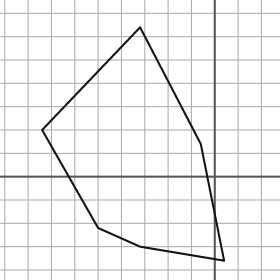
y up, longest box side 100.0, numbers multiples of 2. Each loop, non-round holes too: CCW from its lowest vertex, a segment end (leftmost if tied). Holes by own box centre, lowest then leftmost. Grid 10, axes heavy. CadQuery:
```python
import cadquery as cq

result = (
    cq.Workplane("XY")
    .moveTo(4.0, -36.0)
    .lineTo(-6.0, 14.0)
    .lineTo(-32.0, 64.0)
    .lineTo(-74.0, 20.0)
    .lineTo(-50.0, -22.0)
    .lineTo(-32.0, -30.0)
    .close()
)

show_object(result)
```